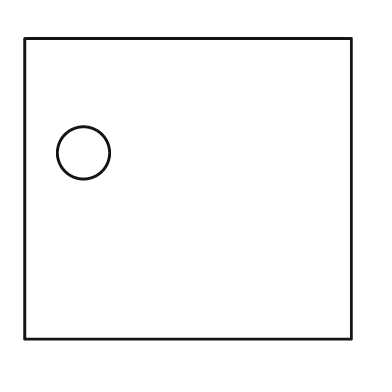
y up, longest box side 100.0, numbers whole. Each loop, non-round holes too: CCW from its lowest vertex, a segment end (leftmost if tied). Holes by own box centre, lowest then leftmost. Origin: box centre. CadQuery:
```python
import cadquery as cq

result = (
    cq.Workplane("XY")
    .moveTo(-50.0, -46.0)
    .lineTo(50.0, -46.0)
    .lineTo(50.0, 46.0)
    .lineTo(-50.0, 46.0)
    .close()
    .moveTo(-32.0, 11.0)
    .circle(8.0)
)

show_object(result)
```